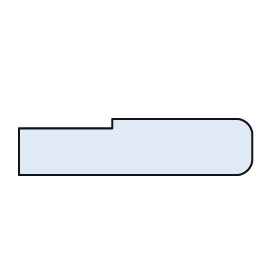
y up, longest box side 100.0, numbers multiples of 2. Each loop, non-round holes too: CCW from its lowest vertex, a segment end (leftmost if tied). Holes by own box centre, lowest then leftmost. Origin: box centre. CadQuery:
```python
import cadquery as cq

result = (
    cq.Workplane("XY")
    .moveTo(-50.0, -12.0)
    .lineTo(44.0, -12.0)
    .threePointArc((48.0, -10.0), (50.0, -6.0))
    .lineTo(50.0, 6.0)
    .threePointArc((48.0, 10.0), (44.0, 12.0))
    .lineTo(-10.0, 12.0)
    .lineTo(-10.0, 8.0)
    .lineTo(-50.0, 8.0)
    .close()
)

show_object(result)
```